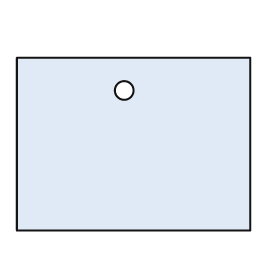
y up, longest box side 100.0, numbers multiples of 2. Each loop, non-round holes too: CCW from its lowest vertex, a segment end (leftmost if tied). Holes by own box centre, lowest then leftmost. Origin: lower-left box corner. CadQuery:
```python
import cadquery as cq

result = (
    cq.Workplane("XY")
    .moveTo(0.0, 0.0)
    .lineTo(100.0, 0.0)
    .lineTo(100.0, 74.0)
    .lineTo(0.0, 74.0)
    .close()
    .moveTo(46.0, 60.0)
    .circle(4.0)
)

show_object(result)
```